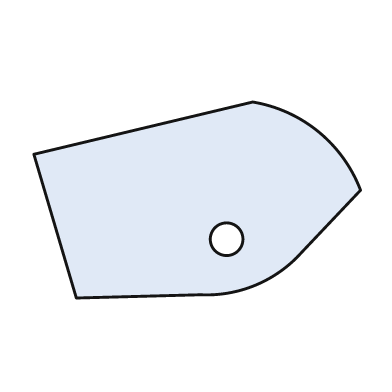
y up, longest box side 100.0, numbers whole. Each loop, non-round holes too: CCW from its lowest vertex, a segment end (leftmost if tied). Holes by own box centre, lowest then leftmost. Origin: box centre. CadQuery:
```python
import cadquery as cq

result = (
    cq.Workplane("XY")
    .moveTo(-37.0, -30.0)
    .lineTo(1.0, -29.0)
    .threePointArc((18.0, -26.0), (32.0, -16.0))
    .lineTo(50.0, 3.0)
    .threePointArc((37.0, 21.0), (17.0, 30.0))
    .lineTo(-50.0, 14.0)
    .close()
    .moveTo(9.0, -12.0)
    .circle(5.0)
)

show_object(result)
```